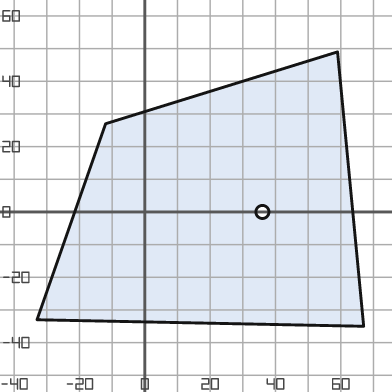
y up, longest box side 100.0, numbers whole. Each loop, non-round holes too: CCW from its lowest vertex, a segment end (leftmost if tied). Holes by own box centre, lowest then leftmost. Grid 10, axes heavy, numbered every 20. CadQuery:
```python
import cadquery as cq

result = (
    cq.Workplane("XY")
    .moveTo(67.0, -35.0)
    .lineTo(59.0, 49.0)
    .lineTo(-12.0, 27.0)
    .lineTo(-33.0, -33.0)
    .close()
    .moveTo(36.0, 0.0)
    .circle(2.0)
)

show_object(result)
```